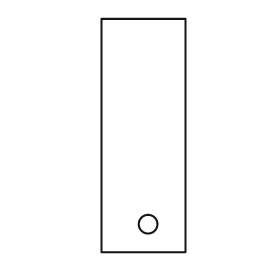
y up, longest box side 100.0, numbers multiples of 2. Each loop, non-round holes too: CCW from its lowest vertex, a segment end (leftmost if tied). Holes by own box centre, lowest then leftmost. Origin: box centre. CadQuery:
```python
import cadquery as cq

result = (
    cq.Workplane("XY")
    .moveTo(-18.0, -50.0)
    .lineTo(18.0, -50.0)
    .lineTo(18.0, 50.0)
    .lineTo(-18.0, 50.0)
    .close()
    .moveTo(2.0, -38.0)
    .circle(4.0)
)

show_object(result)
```